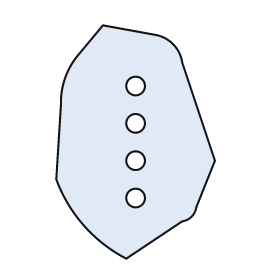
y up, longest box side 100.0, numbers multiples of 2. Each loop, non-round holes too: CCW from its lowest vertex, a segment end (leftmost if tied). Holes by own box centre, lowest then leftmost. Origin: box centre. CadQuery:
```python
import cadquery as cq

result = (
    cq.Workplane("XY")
    .moveTo(-4.0, -50.0)
    .lineTo(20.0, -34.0)
    .threePointArc((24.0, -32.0), (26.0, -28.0))
    .lineTo(34.0, -8.0)
    .lineTo(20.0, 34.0)
    .threePointArc((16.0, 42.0), (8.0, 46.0))
    .lineTo(-14.0, 50.0)
    .lineTo(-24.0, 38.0)
    .threePointArc((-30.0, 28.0), (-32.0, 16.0))
    .lineTo(-34.0, -16.0)
    .threePointArc((-22.0, -36.0), (-4.0, -50.0))
    .close()
    .moveTo(0.0, -24.0)
    .circle(4.0)
    .moveTo(0.0, -8.0)
    .circle(4.0)
    .moveTo(0.0, 8.0)
    .circle(4.0)
    .moveTo(0.0, 24.0)
    .circle(4.0)
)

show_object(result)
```